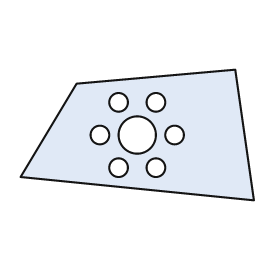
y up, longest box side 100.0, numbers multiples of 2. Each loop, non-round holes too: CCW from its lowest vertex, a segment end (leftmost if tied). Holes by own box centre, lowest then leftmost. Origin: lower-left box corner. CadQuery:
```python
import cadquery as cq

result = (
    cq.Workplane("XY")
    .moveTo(100.0, 0.0)
    .lineTo(92.0, 56.0)
    .lineTo(24.0, 50.0)
    .lineTo(0.0, 10.0)
    .close()
    .moveTo(42.0, 14.0)
    .circle(4.0)
    .moveTo(58.0, 14.0)
    .circle(4.0)
    .moveTo(34.0, 28.0)
    .circle(4.0)
    .moveTo(50.0, 28.0)
    .circle(8.0)
    .moveTo(66.0, 28.0)
    .circle(4.0)
    .moveTo(42.0, 42.0)
    .circle(4.0)
    .moveTo(58.0, 42.0)
    .circle(4.0)
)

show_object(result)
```